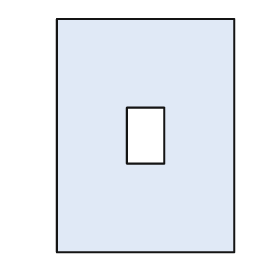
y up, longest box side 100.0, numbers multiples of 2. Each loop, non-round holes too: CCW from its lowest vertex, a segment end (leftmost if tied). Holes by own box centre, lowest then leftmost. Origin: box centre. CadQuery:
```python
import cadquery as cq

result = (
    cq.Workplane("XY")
    .moveTo(-38.0, -50.0)
    .lineTo(38.0, -50.0)
    .lineTo(38.0, 50.0)
    .lineTo(-38.0, 50.0)
    .close()
    .moveTo(-8.0, -12.0)
    .lineTo(8.0, -12.0)
    .lineTo(8.0, 12.0)
    .lineTo(-8.0, 12.0)
    .close()
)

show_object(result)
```